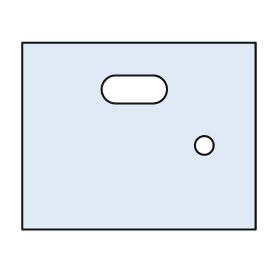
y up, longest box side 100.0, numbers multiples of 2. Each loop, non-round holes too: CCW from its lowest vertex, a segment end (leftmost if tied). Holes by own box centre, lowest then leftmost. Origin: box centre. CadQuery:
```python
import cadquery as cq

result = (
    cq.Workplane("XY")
    .moveTo(-50.0, -40.0)
    .lineTo(50.0, -40.0)
    .lineTo(50.0, 40.0)
    .lineTo(-50.0, 40.0)
    .close()
    .moveTo(28.0, -4.0)
    .circle(4.0)
    .moveTo(-10.0, 14.0)
    .lineTo(6.0, 14.0)
    .threePointArc((12.0, 20.0), (6.0, 26.0))
    .lineTo(-10.0, 26.0)
    .threePointArc((-16.0, 20.0), (-10.0, 14.0))
    .close()
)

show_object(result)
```